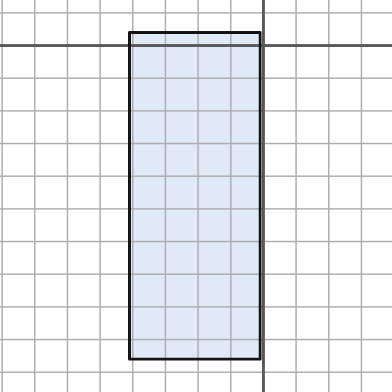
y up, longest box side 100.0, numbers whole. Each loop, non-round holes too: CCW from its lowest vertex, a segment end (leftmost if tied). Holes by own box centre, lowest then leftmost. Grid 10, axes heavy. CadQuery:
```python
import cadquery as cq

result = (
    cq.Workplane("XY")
    .moveTo(-41.0, -96.0)
    .lineTo(-1.0, -96.0)
    .lineTo(-1.0, 4.0)
    .lineTo(-41.0, 4.0)
    .close()
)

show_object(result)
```